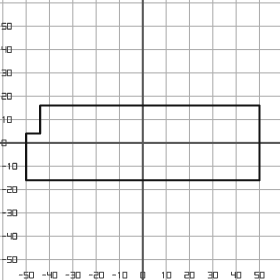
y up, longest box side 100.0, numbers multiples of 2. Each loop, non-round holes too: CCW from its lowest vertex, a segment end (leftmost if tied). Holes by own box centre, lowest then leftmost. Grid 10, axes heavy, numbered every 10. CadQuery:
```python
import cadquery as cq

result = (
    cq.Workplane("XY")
    .moveTo(-50.0, -16.0)
    .lineTo(50.0, -16.0)
    .lineTo(50.0, 16.0)
    .lineTo(-44.0, 16.0)
    .lineTo(-44.0, 4.0)
    .lineTo(-50.0, 4.0)
    .close()
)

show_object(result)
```